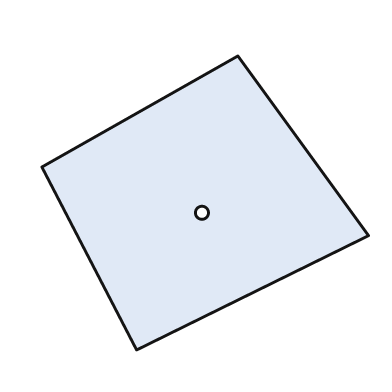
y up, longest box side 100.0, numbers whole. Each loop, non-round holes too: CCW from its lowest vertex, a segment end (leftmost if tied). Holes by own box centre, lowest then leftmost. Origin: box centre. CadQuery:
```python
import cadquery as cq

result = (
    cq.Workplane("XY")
    .moveTo(-21.0, -45.0)
    .lineTo(50.0, -10.0)
    .lineTo(10.0, 45.0)
    .lineTo(-50.0, 11.0)
    .close()
    .moveTo(-1.0, -3.0)
    .circle(2.0)
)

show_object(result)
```